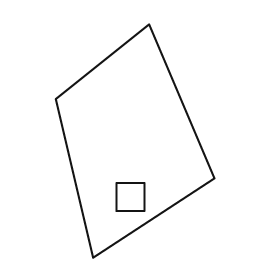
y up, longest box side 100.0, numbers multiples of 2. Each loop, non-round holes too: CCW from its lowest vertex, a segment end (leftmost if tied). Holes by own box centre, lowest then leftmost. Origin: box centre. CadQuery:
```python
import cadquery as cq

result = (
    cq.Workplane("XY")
    .moveTo(-18.0, -50.0)
    .lineTo(34.0, -16.0)
    .lineTo(6.0, 50.0)
    .lineTo(-34.0, 18.0)
    .close()
    .moveTo(-8.0, -30.0)
    .lineTo(4.0, -30.0)
    .lineTo(4.0, -18.0)
    .lineTo(-8.0, -18.0)
    .close()
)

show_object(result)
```